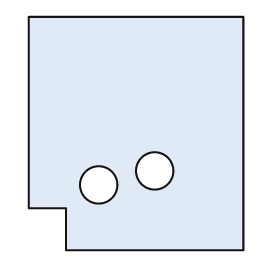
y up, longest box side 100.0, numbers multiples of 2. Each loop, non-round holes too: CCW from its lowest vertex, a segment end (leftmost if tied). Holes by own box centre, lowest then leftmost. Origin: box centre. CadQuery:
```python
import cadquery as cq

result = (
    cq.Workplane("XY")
    .moveTo(-30.0, -50.0)
    .lineTo(46.0, -50.0)
    .lineTo(46.0, 50.0)
    .lineTo(-46.0, 50.0)
    .lineTo(-46.0, -32.0)
    .lineTo(-30.0, -32.0)
    .close()
    .moveTo(-16.0, -22.0)
    .circle(8.0)
    .moveTo(8.0, -16.0)
    .circle(8.0)
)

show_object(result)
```